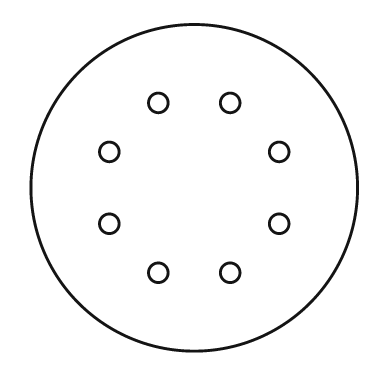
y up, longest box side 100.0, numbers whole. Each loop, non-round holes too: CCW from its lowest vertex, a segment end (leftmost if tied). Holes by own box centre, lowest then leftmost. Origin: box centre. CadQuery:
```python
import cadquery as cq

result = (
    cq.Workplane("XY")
    .moveTo(0.0, 0.0)
    .circle(50.0)
    .moveTo(-11.0, -26.0)
    .circle(3.0)
    .moveTo(11.0, -26.0)
    .circle(3.0)
    .moveTo(-26.0, -11.0)
    .circle(3.0)
    .moveTo(26.0, -11.0)
    .circle(3.0)
    .moveTo(-26.0, 11.0)
    .circle(3.0)
    .moveTo(26.0, 11.0)
    .circle(3.0)
    .moveTo(-11.0, 26.0)
    .circle(3.0)
    .moveTo(11.0, 26.0)
    .circle(3.0)
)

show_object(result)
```